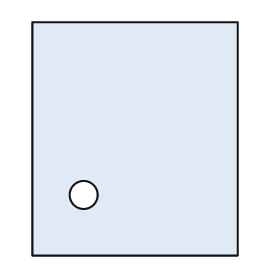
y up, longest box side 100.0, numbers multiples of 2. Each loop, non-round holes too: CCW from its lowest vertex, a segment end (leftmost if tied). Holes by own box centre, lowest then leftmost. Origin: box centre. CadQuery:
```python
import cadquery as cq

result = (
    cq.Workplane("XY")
    .moveTo(-44.0, -50.0)
    .lineTo(44.0, -50.0)
    .lineTo(44.0, 50.0)
    .lineTo(-44.0, 50.0)
    .close()
    .moveTo(-22.0, -24.0)
    .circle(6.0)
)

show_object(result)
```